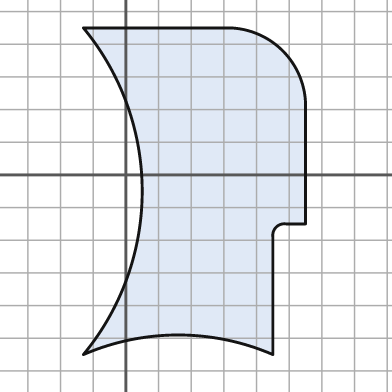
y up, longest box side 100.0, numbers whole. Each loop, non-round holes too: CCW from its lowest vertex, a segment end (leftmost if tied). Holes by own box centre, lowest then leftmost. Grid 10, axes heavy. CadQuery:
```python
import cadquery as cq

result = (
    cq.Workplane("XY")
    .moveTo(-13.0, -55.0)
    .threePointArc((16.0, -49.0), (45.0, -55.0))
    .lineTo(45.0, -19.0)
    .threePointArc((46.0, -16.0), (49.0, -15.0))
    .lineTo(55.0, -15.0)
    .lineTo(55.0, 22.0)
    .threePointArc((48.0, 38.0), (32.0, 45.0))
    .lineTo(-13.0, 45.0)
    .threePointArc((5.0, -5.0), (-13.0, -55.0))
    .close()
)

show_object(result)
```